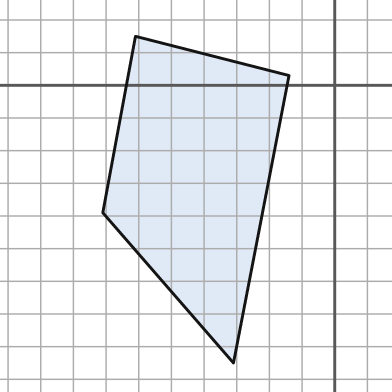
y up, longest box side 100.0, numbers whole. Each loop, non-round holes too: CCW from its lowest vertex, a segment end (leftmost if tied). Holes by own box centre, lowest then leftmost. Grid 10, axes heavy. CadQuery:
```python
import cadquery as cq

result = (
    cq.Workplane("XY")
    .moveTo(-31.0, -85.0)
    .lineTo(-14.0, 3.0)
    .lineTo(-61.0, 15.0)
    .lineTo(-71.0, -39.0)
    .close()
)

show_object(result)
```